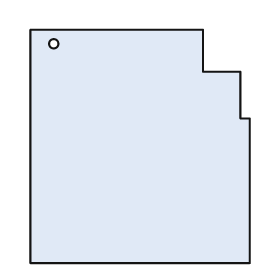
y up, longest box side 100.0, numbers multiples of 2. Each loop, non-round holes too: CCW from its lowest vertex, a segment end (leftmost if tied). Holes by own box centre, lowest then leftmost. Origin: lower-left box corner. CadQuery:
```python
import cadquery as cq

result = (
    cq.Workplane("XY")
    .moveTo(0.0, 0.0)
    .lineTo(94.0, 0.0)
    .lineTo(94.0, 62.0)
    .lineTo(90.0, 62.0)
    .lineTo(90.0, 82.0)
    .lineTo(74.0, 82.0)
    .lineTo(74.0, 100.0)
    .lineTo(0.0, 100.0)
    .close()
    .moveTo(10.0, 94.0)
    .circle(2.0)
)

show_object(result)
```